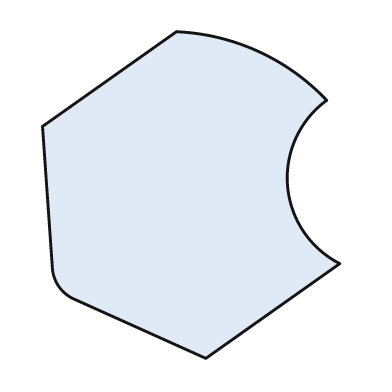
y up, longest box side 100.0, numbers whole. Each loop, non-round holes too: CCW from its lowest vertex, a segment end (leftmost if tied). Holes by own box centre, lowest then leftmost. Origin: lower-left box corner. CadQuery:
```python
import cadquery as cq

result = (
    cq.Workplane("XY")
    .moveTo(50.0, 0.0)
    .lineTo(91.0, 29.0)
    .threePointArc((75.0, 53.0), (87.0, 79.0))
    .threePointArc((66.0, 94.0), (41.0, 100.0))
    .lineTo(0.0, 71.0)
    .lineTo(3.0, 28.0)
    .threePointArc((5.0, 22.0), (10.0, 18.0))
    .close()
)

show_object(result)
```